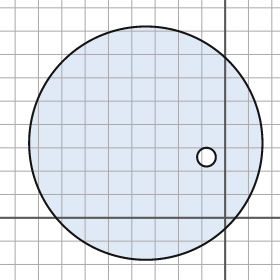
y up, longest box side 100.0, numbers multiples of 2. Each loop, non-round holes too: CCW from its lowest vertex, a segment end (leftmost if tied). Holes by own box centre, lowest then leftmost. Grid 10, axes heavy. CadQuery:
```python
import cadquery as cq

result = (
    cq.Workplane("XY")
    .moveTo(-34.0, 32.0)
    .circle(50.0)
    .moveTo(-8.0, 26.0)
    .circle(4.0)
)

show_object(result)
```